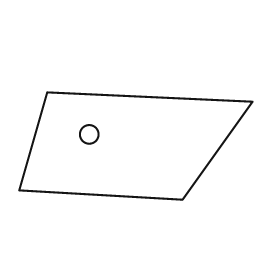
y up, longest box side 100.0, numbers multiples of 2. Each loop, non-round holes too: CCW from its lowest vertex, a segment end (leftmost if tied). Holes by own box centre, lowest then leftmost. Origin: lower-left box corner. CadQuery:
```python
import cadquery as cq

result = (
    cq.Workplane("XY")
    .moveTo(70.0, 0.0)
    .lineTo(100.0, 42.0)
    .lineTo(12.0, 46.0)
    .lineTo(0.0, 4.0)
    .close()
    .moveTo(30.0, 28.0)
    .circle(4.0)
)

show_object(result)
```